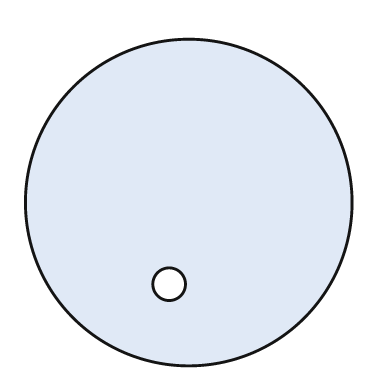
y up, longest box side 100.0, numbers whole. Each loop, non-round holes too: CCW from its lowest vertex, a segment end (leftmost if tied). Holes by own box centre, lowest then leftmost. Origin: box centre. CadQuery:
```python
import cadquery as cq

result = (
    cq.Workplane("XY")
    .moveTo(0.0, 0.0)
    .circle(50.0)
    .moveTo(-6.0, -25.0)
    .circle(5.0)
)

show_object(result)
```